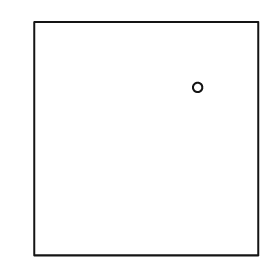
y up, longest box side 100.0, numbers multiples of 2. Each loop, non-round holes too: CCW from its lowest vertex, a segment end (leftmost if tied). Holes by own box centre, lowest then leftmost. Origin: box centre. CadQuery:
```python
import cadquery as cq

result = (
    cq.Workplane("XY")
    .moveTo(-48.0, -50.0)
    .lineTo(48.0, -50.0)
    .lineTo(48.0, 50.0)
    .lineTo(-48.0, 50.0)
    .close()
    .moveTo(22.0, 22.0)
    .circle(2.0)
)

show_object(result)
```